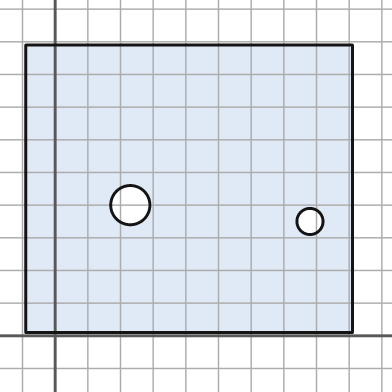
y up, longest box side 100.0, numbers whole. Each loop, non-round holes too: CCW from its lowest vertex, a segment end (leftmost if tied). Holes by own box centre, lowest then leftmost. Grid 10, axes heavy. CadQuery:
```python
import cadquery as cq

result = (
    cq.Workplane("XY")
    .moveTo(-9.0, 1.0)
    .lineTo(91.0, 1.0)
    .lineTo(91.0, 89.0)
    .lineTo(-9.0, 89.0)
    .close()
    .moveTo(78.0, 35.0)
    .circle(4.0)
    .moveTo(23.0, 40.0)
    .circle(6.0)
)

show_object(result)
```